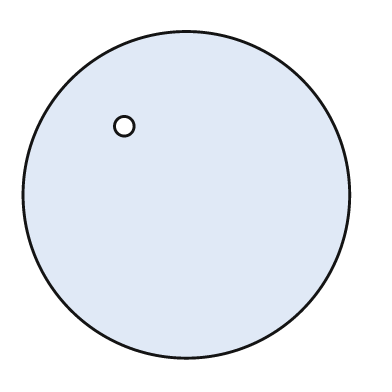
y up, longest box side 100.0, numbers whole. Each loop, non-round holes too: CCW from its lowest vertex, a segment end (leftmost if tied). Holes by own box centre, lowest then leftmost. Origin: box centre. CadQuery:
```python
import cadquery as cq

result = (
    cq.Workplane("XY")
    .moveTo(0.0, 0.0)
    .circle(50.0)
    .moveTo(-19.0, 21.0)
    .circle(3.0)
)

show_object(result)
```